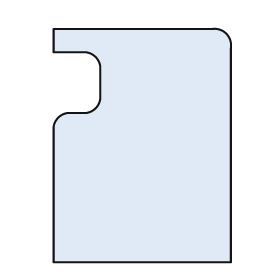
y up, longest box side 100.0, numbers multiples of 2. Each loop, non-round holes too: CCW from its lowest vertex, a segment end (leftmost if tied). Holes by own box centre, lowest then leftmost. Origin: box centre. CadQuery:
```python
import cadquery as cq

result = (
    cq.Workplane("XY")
    .moveTo(-38.0, -50.0)
    .lineTo(38.0, -50.0)
    .lineTo(38.0, 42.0)
    .threePointArc((36.0, 48.0), (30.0, 50.0))
    .lineTo(-38.0, 50.0)
    .lineTo(-38.0, 40.0)
    .lineTo(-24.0, 40.0)
    .threePointArc((-20.0, 38.0), (-18.0, 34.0))
    .lineTo(-18.0, 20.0)
    .threePointArc((-20.0, 16.0), (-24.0, 14.0))
    .lineTo(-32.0, 14.0)
    .threePointArc((-36.0, 12.0), (-38.0, 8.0))
    .close()
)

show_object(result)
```